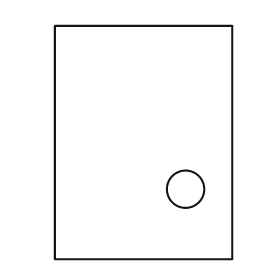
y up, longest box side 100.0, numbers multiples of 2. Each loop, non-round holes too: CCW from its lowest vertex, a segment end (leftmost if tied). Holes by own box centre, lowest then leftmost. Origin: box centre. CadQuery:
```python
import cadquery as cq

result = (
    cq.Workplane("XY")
    .moveTo(-38.0, -50.0)
    .lineTo(38.0, -50.0)
    .lineTo(38.0, 50.0)
    .lineTo(-38.0, 50.0)
    .close()
    .moveTo(18.0, -20.0)
    .circle(8.0)
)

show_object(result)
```